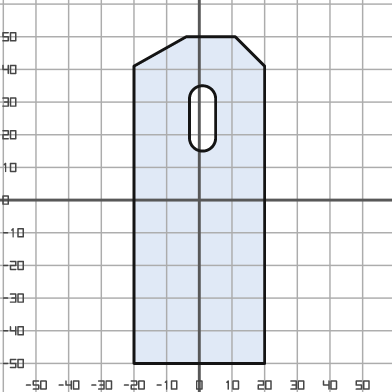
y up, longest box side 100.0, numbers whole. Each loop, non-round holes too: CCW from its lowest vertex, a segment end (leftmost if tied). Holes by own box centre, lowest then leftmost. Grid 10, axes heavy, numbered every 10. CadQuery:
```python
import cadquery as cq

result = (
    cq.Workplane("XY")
    .moveTo(-20.0, -50.0)
    .lineTo(20.0, -50.0)
    .lineTo(20.0, 41.0)
    .lineTo(11.0, 50.0)
    .lineTo(-4.0, 50.0)
    .lineTo(-20.0, 41.0)
    .close()
    .moveTo(-3.0, 19.0)
    .threePointArc((1.0, 15.0), (5.0, 19.0))
    .lineTo(5.0, 31.0)
    .threePointArc((1.0, 35.0), (-3.0, 31.0))
    .close()
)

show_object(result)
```